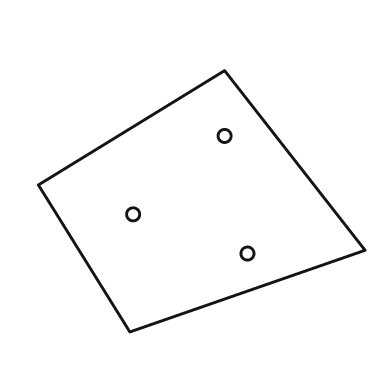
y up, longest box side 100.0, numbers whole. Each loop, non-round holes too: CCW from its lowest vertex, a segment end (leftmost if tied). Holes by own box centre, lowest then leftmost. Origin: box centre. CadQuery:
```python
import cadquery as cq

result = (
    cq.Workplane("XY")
    .moveTo(-22.0, -40.0)
    .lineTo(50.0, -15.0)
    .lineTo(7.0, 40.0)
    .lineTo(-50.0, 5.0)
    .close()
    .moveTo(14.0, -16.0)
    .circle(2.0)
    .moveTo(-21.0, -4.0)
    .circle(2.0)
    .moveTo(7.0, 20.0)
    .circle(2.0)
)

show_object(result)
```